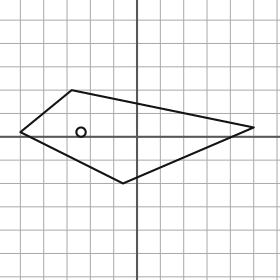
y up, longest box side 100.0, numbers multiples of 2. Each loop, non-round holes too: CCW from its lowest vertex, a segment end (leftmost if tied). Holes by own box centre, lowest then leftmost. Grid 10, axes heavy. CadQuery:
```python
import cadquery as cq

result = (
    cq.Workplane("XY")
    .moveTo(-6.0, -20.0)
    .lineTo(50.0, 4.0)
    .lineTo(-28.0, 20.0)
    .lineTo(-50.0, 2.0)
    .close()
    .moveTo(-24.0, 2.0)
    .circle(2.0)
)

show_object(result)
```